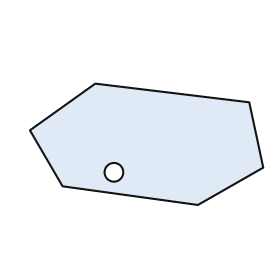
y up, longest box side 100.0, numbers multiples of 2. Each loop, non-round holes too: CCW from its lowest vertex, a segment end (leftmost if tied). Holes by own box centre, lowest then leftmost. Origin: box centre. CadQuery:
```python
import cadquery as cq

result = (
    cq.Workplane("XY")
    .moveTo(22.0, -26.0)
    .lineTo(50.0, -10.0)
    .lineTo(44.0, 18.0)
    .lineTo(-22.0, 26.0)
    .lineTo(-50.0, 6.0)
    .lineTo(-36.0, -18.0)
    .close()
    .moveTo(-14.0, -12.0)
    .circle(4.0)
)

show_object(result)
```